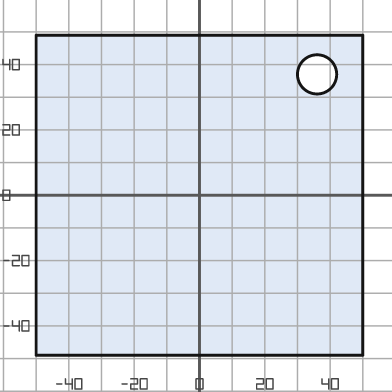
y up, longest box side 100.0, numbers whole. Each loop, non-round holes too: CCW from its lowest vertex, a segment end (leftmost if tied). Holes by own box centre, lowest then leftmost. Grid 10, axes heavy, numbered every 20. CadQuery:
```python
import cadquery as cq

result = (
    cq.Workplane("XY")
    .moveTo(-50.0, -49.0)
    .lineTo(50.0, -49.0)
    .lineTo(50.0, 49.0)
    .lineTo(-50.0, 49.0)
    .close()
    .moveTo(36.0, 37.0)
    .circle(6.0)
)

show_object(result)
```